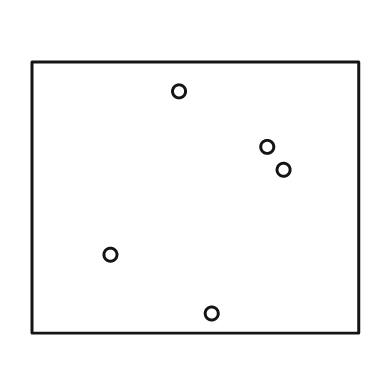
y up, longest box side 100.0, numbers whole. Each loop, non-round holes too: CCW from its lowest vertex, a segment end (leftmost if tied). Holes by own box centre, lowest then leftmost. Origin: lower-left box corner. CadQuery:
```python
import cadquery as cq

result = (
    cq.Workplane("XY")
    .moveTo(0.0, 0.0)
    .lineTo(100.0, 0.0)
    .lineTo(100.0, 83.0)
    .lineTo(0.0, 83.0)
    .close()
    .moveTo(55.0, 6.0)
    .circle(2.0)
    .moveTo(24.0, 24.0)
    .circle(2.0)
    .moveTo(77.0, 50.0)
    .circle(2.0)
    .moveTo(72.0, 57.0)
    .circle(2.0)
    .moveTo(45.0, 74.0)
    .circle(2.0)
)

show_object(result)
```